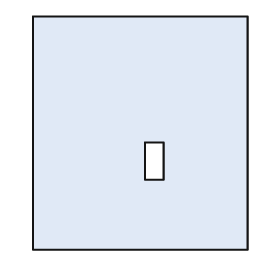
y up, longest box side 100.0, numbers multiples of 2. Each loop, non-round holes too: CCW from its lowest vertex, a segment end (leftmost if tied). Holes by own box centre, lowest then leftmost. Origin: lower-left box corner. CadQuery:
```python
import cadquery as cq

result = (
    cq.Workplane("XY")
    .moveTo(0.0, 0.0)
    .lineTo(92.0, 0.0)
    .lineTo(92.0, 100.0)
    .lineTo(0.0, 100.0)
    .close()
    .moveTo(48.0, 30.0)
    .lineTo(56.0, 30.0)
    .lineTo(56.0, 46.0)
    .lineTo(48.0, 46.0)
    .close()
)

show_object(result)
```